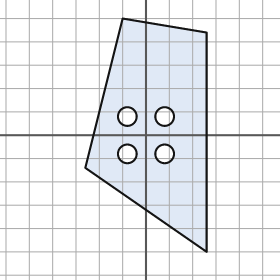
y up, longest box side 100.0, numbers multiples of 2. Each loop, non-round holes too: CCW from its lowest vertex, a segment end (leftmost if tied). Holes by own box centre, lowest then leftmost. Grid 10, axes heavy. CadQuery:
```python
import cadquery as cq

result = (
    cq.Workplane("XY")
    .moveTo(26.0, -50.0)
    .lineTo(26.0, 44.0)
    .lineTo(-10.0, 50.0)
    .lineTo(-26.0, -14.0)
    .close()
    .moveTo(-8.0, -8.0)
    .circle(4.0)
    .moveTo(8.0, -8.0)
    .circle(4.0)
    .moveTo(-8.0, 8.0)
    .circle(4.0)
    .moveTo(8.0, 8.0)
    .circle(4.0)
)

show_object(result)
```